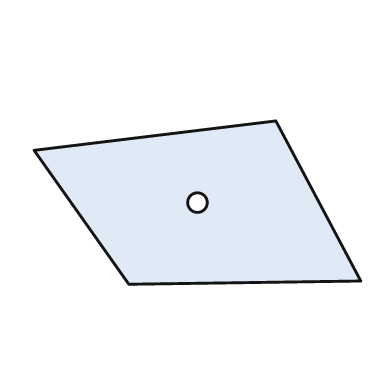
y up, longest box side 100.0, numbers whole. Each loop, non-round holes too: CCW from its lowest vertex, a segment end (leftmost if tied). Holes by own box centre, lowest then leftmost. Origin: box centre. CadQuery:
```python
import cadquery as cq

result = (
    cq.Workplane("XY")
    .moveTo(-21.0, -25.0)
    .lineTo(50.0, -24.0)
    .lineTo(24.0, 25.0)
    .lineTo(-50.0, 16.0)
    .close()
    .moveTo(0.0, 0.0)
    .circle(3.0)
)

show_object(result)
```